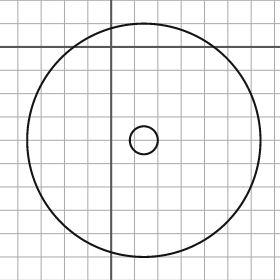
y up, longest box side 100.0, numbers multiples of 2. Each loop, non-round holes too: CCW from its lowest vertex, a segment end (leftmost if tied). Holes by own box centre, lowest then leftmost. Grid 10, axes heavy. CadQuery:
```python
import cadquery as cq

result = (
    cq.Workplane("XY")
    .moveTo(14.0, -40.0)
    .circle(50.0)
    .moveTo(14.0, -40.0)
    .circle(6.0)
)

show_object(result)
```